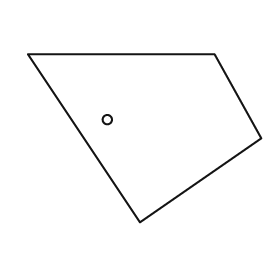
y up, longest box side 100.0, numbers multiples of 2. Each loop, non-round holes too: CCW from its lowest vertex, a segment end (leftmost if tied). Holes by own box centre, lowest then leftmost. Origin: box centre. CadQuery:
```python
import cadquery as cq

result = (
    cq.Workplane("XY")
    .moveTo(-2.0, -36.0)
    .lineTo(50.0, 0.0)
    .lineTo(30.0, 36.0)
    .lineTo(-50.0, 36.0)
    .close()
    .moveTo(-16.0, 8.0)
    .circle(2.0)
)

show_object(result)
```